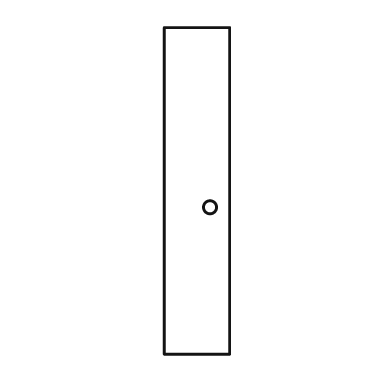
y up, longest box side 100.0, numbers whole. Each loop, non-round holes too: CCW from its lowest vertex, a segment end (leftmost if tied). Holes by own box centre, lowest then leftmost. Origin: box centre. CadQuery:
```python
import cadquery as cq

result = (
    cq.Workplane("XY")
    .moveTo(-10.0, -50.0)
    .lineTo(10.0, -50.0)
    .lineTo(10.0, 50.0)
    .lineTo(-10.0, 50.0)
    .close()
    .moveTo(4.0, -5.0)
    .circle(2.0)
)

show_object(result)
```